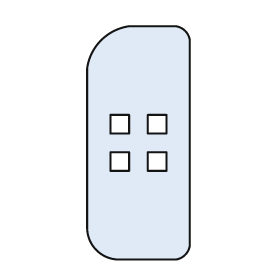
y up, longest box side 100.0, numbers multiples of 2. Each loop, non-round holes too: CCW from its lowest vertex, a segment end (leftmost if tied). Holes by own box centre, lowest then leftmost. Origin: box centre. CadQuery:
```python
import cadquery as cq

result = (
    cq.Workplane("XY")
    .moveTo(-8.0, -50.0)
    .lineTo(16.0, -50.0)
    .threePointArc((20.0, -48.0), (22.0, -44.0))
    .lineTo(22.0, 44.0)
    .threePointArc((20.0, 48.0), (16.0, 50.0))
    .lineTo(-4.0, 50.0)
    .threePointArc((-16.0, 44.0), (-22.0, 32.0))
    .lineTo(-22.0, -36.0)
    .threePointArc((-18.0, -46.0), (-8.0, -50.0))
    .close()
    .moveTo(-12.0, -12.0)
    .lineTo(-4.0, -12.0)
    .lineTo(-4.0, -4.0)
    .lineTo(-12.0, -4.0)
    .close()
    .moveTo(4.0, -12.0)
    .lineTo(12.0, -12.0)
    .lineTo(12.0, -4.0)
    .lineTo(4.0, -4.0)
    .close()
    .moveTo(-12.0, 4.0)
    .lineTo(-4.0, 4.0)
    .lineTo(-4.0, 12.0)
    .lineTo(-12.0, 12.0)
    .close()
    .moveTo(4.0, 4.0)
    .lineTo(12.0, 4.0)
    .lineTo(12.0, 12.0)
    .lineTo(4.0, 12.0)
    .close()
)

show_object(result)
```